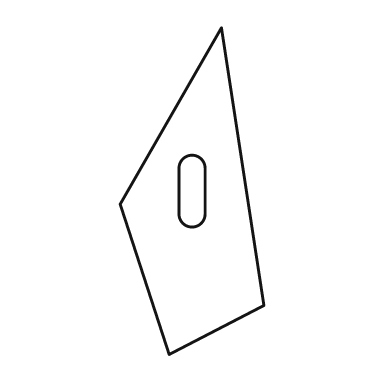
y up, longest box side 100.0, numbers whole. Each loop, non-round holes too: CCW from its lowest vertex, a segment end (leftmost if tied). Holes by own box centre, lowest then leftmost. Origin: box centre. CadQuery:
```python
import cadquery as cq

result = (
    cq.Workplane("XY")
    .moveTo(-7.0, -50.0)
    .lineTo(22.0, -35.0)
    .lineTo(9.0, 50.0)
    .lineTo(-22.0, -4.0)
    .close()
    .moveTo(-4.0, -7.0)
    .threePointArc((0.0, -11.0), (4.0, -7.0))
    .lineTo(4.0, 7.0)
    .threePointArc((0.0, 11.0), (-4.0, 7.0))
    .close()
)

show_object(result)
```